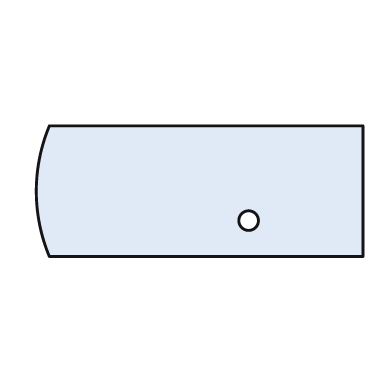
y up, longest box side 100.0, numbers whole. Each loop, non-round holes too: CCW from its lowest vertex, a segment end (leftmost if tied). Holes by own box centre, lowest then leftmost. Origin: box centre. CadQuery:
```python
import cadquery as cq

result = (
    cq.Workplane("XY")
    .moveTo(-46.0, -20.0)
    .lineTo(50.0, -20.0)
    .lineTo(50.0, 20.0)
    .lineTo(-46.0, 20.0)
    .threePointArc((-50.0, 0.0), (-46.0, -20.0))
    .close()
    .moveTo(15.0, -9.0)
    .circle(3.0)
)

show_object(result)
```